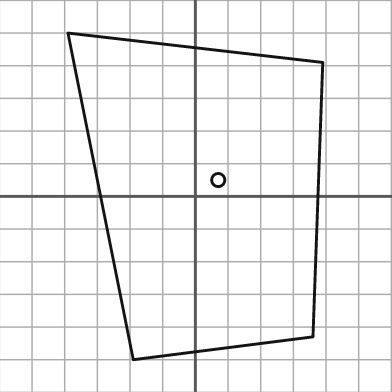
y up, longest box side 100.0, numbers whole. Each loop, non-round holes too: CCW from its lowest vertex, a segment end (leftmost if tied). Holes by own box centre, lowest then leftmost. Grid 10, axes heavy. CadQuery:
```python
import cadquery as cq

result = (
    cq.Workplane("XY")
    .moveTo(-19.0, -50.0)
    .lineTo(36.0, -43.0)
    .lineTo(39.0, 41.0)
    .lineTo(-39.0, 50.0)
    .close()
    .moveTo(7.0, 5.0)
    .circle(2.0)
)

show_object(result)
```